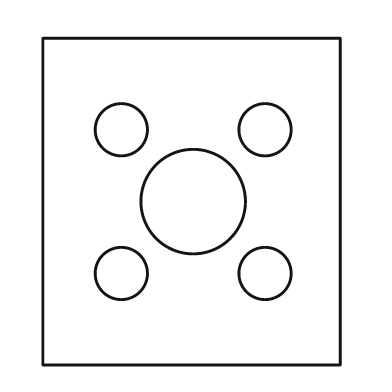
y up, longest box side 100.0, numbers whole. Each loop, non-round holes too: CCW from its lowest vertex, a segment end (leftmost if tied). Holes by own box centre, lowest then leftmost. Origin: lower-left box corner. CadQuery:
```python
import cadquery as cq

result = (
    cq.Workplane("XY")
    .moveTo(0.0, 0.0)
    .lineTo(91.0, 0.0)
    .lineTo(91.0, 100.0)
    .lineTo(0.0, 100.0)
    .close()
    .moveTo(24.0, 28.0)
    .circle(8.0)
    .moveTo(68.0, 28.0)
    .circle(8.0)
    .moveTo(46.0, 50.0)
    .circle(16.0)
    .moveTo(24.0, 72.0)
    .circle(8.0)
    .moveTo(68.0, 72.0)
    .circle(8.0)
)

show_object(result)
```